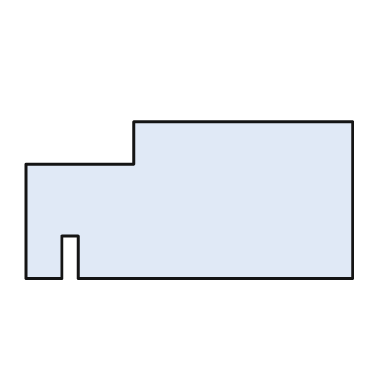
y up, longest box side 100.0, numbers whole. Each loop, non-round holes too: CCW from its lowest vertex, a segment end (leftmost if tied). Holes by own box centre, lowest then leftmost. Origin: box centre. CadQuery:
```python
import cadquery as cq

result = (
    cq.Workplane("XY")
    .moveTo(-50.0, -24.0)
    .lineTo(-39.0, -24.0)
    .lineTo(-39.0, -11.0)
    .lineTo(-34.0, -11.0)
    .lineTo(-34.0, -24.0)
    .lineTo(50.0, -24.0)
    .lineTo(50.0, 24.0)
    .lineTo(-17.0, 24.0)
    .lineTo(-17.0, 11.0)
    .lineTo(-50.0, 11.0)
    .close()
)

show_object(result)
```